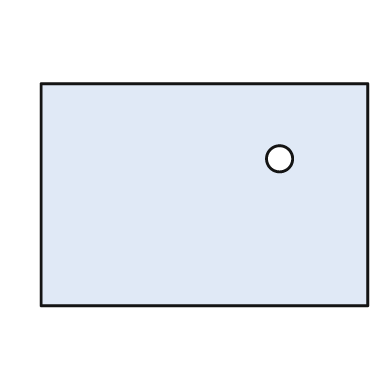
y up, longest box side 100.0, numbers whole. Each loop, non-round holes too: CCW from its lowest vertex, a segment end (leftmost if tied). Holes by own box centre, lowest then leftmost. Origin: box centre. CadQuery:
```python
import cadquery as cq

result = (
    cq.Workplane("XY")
    .moveTo(-50.0, -34.0)
    .lineTo(50.0, -34.0)
    .lineTo(50.0, 34.0)
    .lineTo(-50.0, 34.0)
    .close()
    .moveTo(23.0, 11.0)
    .circle(4.0)
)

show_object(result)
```